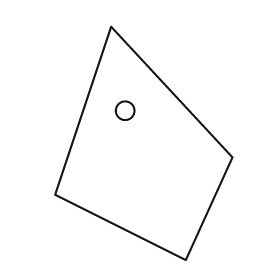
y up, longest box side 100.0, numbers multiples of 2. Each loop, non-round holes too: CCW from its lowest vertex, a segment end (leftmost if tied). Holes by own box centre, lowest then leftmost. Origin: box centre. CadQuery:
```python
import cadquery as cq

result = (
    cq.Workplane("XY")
    .moveTo(18.0, -50.0)
    .lineTo(38.0, -6.0)
    .lineTo(-14.0, 50.0)
    .lineTo(-38.0, -22.0)
    .close()
    .moveTo(-8.0, 14.0)
    .circle(4.0)
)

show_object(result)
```